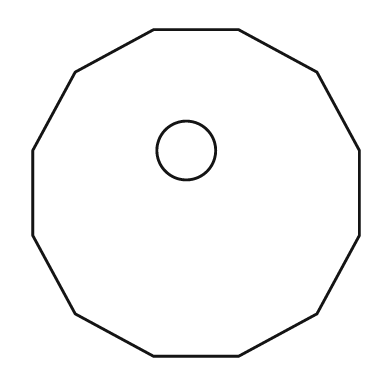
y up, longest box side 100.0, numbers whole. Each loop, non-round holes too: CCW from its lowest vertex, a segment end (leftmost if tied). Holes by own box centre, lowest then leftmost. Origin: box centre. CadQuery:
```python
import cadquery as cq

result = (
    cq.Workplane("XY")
    .moveTo(-13.0, -50.0)
    .lineTo(13.0, -50.0)
    .lineTo(37.0, -37.0)
    .lineTo(50.0, -13.0)
    .lineTo(50.0, 13.0)
    .lineTo(37.0, 37.0)
    .lineTo(13.0, 50.0)
    .lineTo(-13.0, 50.0)
    .lineTo(-37.0, 37.0)
    .lineTo(-50.0, 13.0)
    .lineTo(-50.0, -13.0)
    .lineTo(-37.0, -37.0)
    .close()
    .moveTo(-3.0, 13.0)
    .circle(9.0)
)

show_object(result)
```